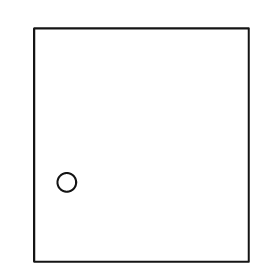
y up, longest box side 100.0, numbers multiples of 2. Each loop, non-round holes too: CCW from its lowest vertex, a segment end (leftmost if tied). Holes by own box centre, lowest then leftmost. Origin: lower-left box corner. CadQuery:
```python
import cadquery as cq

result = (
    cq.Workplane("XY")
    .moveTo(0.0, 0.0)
    .lineTo(92.0, 0.0)
    .lineTo(92.0, 100.0)
    .lineTo(0.0, 100.0)
    .close()
    .moveTo(14.0, 34.0)
    .circle(4.0)
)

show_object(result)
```